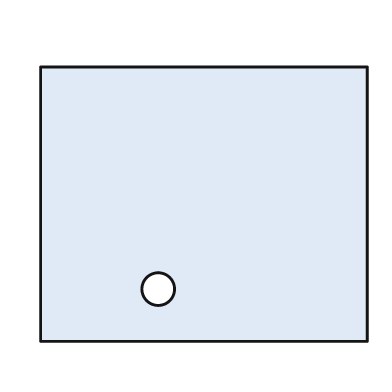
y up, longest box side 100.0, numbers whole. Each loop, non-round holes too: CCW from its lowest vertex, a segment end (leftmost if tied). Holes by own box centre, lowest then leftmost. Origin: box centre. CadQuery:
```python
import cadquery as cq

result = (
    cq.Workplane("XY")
    .moveTo(-50.0, -42.0)
    .lineTo(50.0, -42.0)
    .lineTo(50.0, 42.0)
    .lineTo(-50.0, 42.0)
    .close()
    .moveTo(-14.0, -26.0)
    .circle(5.0)
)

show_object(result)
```